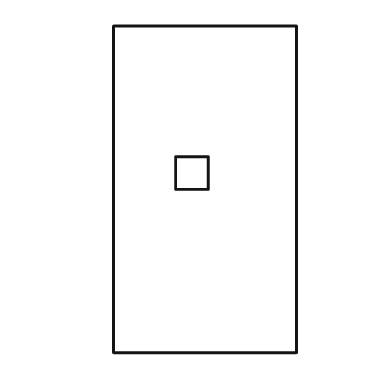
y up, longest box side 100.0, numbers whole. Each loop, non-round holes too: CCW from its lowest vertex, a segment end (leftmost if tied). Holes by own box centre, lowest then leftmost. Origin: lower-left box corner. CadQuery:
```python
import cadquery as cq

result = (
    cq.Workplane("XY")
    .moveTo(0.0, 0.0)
    .lineTo(56.0, 0.0)
    .lineTo(56.0, 100.0)
    .lineTo(0.0, 100.0)
    .close()
    .moveTo(19.0, 50.0)
    .lineTo(29.0, 50.0)
    .lineTo(29.0, 60.0)
    .lineTo(19.0, 60.0)
    .close()
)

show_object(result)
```